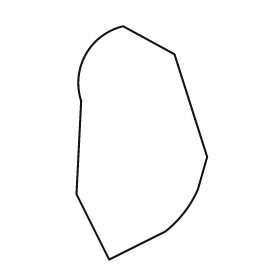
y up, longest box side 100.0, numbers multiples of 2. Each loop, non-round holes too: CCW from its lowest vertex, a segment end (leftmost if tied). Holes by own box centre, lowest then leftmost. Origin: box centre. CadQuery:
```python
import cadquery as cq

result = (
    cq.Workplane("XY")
    .moveTo(-14.0, -50.0)
    .lineTo(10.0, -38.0)
    .threePointArc((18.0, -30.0), (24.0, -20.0))
    .lineTo(28.0, -6.0)
    .lineTo(14.0, 38.0)
    .lineTo(-8.0, 50.0)
    .threePointArc((-24.0, 38.0), (-26.0, 18.0))
    .lineTo(-28.0, -22.0)
    .close()
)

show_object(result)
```